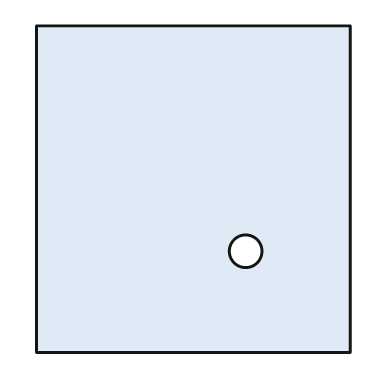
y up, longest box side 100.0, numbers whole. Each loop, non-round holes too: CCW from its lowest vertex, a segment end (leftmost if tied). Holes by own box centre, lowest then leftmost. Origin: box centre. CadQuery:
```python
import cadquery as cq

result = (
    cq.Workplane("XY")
    .moveTo(-48.0, -50.0)
    .lineTo(48.0, -50.0)
    .lineTo(48.0, 50.0)
    .lineTo(-48.0, 50.0)
    .close()
    .moveTo(16.0, -19.0)
    .circle(5.0)
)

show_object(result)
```